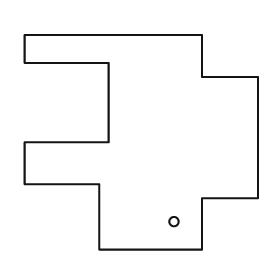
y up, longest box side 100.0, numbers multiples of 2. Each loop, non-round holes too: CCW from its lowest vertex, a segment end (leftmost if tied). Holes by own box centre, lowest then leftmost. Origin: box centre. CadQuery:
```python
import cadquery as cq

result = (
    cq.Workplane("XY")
    .moveTo(-18.0, -46.0)
    .lineTo(26.0, -46.0)
    .lineTo(26.0, -24.0)
    .lineTo(50.0, -24.0)
    .lineTo(50.0, 28.0)
    .lineTo(26.0, 28.0)
    .lineTo(26.0, 46.0)
    .lineTo(-50.0, 46.0)
    .lineTo(-50.0, 34.0)
    .lineTo(-14.0, 34.0)
    .lineTo(-14.0, 0.0)
    .lineTo(-50.0, 0.0)
    .lineTo(-50.0, -18.0)
    .lineTo(-18.0, -18.0)
    .close()
    .moveTo(14.0, -34.0)
    .circle(2.0)
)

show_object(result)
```